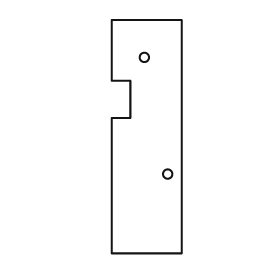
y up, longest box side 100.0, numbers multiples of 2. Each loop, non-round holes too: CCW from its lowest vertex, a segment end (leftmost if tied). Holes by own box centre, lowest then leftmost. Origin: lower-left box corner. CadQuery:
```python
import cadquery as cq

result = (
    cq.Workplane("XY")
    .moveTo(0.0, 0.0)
    .lineTo(30.0, 0.0)
    .lineTo(30.0, 100.0)
    .lineTo(0.0, 100.0)
    .lineTo(0.0, 74.0)
    .lineTo(8.0, 74.0)
    .lineTo(8.0, 58.0)
    .lineTo(0.0, 58.0)
    .close()
    .moveTo(24.0, 34.0)
    .circle(2.0)
    .moveTo(14.0, 84.0)
    .circle(2.0)
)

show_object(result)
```